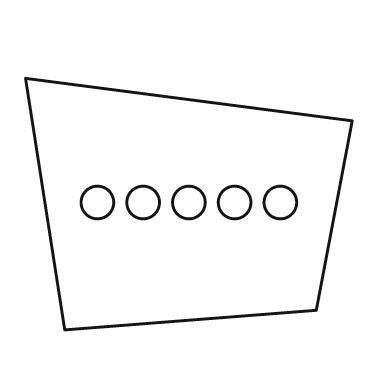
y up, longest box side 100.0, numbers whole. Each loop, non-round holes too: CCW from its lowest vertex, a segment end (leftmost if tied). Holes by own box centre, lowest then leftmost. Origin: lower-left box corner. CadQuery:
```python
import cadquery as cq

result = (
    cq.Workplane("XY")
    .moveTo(12.0, 0.0)
    .lineTo(89.0, 6.0)
    .lineTo(100.0, 64.0)
    .lineTo(0.0, 77.0)
    .close()
    .moveTo(22.0, 39.0)
    .circle(5.0)
    .moveTo(36.0, 39.0)
    .circle(5.0)
    .moveTo(50.0, 39.0)
    .circle(5.0)
    .moveTo(64.0, 39.0)
    .circle(5.0)
    .moveTo(78.0, 39.0)
    .circle(5.0)
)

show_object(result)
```